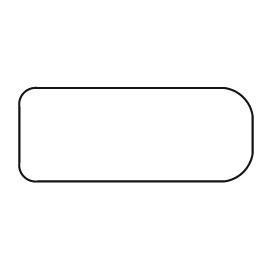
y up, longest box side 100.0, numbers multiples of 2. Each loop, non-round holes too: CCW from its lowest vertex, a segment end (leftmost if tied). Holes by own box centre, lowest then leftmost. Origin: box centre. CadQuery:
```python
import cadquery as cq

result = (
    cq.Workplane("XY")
    .moveTo(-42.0, -20.0)
    .lineTo(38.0, -20.0)
    .threePointArc((46.0, -16.0), (50.0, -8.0))
    .lineTo(50.0, 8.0)
    .threePointArc((46.0, 16.0), (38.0, 20.0))
    .lineTo(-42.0, 20.0)
    .threePointArc((-48.0, 18.0), (-50.0, 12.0))
    .lineTo(-50.0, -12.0)
    .threePointArc((-48.0, -18.0), (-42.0, -20.0))
    .close()
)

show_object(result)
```